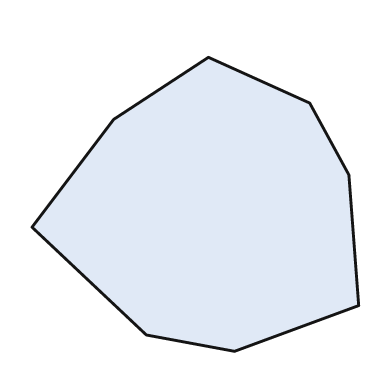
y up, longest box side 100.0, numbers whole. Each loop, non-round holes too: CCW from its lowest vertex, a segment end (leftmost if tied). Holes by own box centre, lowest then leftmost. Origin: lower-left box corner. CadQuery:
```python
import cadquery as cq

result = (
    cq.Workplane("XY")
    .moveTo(62.0, 0.0)
    .lineTo(100.0, 14.0)
    .lineTo(97.0, 54.0)
    .lineTo(85.0, 76.0)
    .lineTo(54.0, 90.0)
    .lineTo(25.0, 71.0)
    .lineTo(0.0, 38.0)
    .lineTo(35.0, 5.0)
    .close()
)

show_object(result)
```